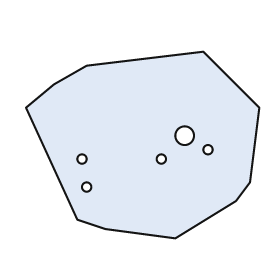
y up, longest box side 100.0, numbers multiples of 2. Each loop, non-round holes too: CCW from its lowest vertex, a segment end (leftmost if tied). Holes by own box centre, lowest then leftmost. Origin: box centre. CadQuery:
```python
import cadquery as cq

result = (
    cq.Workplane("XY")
    .moveTo(14.0, -40.0)
    .lineTo(40.0, -24.0)
    .lineTo(46.0, -16.0)
    .lineTo(50.0, 16.0)
    .lineTo(26.0, 40.0)
    .lineTo(-24.0, 34.0)
    .lineTo(-38.0, 26.0)
    .lineTo(-50.0, 16.0)
    .lineTo(-28.0, -32.0)
    .lineTo(-16.0, -36.0)
    .close()
    .moveTo(-24.0, -18.0)
    .circle(2.0)
    .moveTo(-26.0, -6.0)
    .circle(2.0)
    .moveTo(8.0, -6.0)
    .circle(2.0)
    .moveTo(28.0, -2.0)
    .circle(2.0)
    .moveTo(18.0, 4.0)
    .circle(4.0)
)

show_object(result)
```